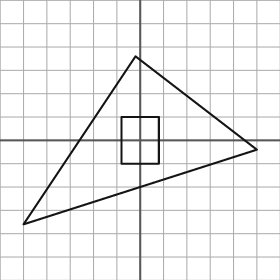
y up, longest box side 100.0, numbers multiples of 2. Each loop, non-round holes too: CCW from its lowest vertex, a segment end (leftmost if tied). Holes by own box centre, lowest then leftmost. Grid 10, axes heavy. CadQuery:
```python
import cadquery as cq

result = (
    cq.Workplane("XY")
    .moveTo(-50.0, -36.0)
    .lineTo(50.0, -4.0)
    .lineTo(-2.0, 36.0)
    .close()
    .moveTo(-8.0, -10.0)
    .lineTo(8.0, -10.0)
    .lineTo(8.0, 10.0)
    .lineTo(-8.0, 10.0)
    .close()
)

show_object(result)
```